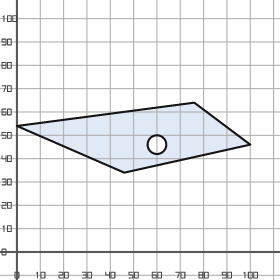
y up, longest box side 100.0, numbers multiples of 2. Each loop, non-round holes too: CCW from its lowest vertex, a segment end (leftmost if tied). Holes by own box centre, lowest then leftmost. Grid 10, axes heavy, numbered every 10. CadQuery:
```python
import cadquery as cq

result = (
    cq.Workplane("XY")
    .moveTo(46.0, 34.0)
    .lineTo(100.0, 46.0)
    .lineTo(76.0, 64.0)
    .lineTo(0.0, 54.0)
    .close()
    .moveTo(60.0, 46.0)
    .circle(4.0)
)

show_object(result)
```